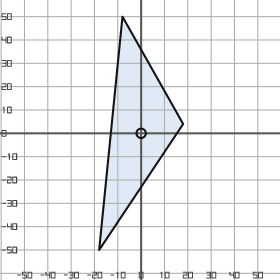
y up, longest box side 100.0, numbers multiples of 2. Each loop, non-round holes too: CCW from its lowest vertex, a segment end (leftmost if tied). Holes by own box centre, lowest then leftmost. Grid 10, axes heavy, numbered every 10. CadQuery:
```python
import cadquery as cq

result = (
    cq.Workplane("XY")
    .moveTo(-18.0, -50.0)
    .lineTo(18.0, 4.0)
    .lineTo(-8.0, 50.0)
    .close()
    .moveTo(0.0, 0.0)
    .circle(2.0)
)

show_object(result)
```